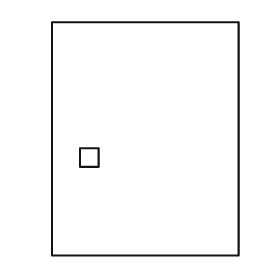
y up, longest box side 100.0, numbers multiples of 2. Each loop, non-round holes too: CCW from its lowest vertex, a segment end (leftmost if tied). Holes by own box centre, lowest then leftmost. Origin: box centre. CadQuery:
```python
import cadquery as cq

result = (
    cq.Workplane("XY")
    .moveTo(-40.0, -50.0)
    .lineTo(40.0, -50.0)
    .lineTo(40.0, 50.0)
    .lineTo(-40.0, 50.0)
    .close()
    .moveTo(-28.0, -12.0)
    .lineTo(-20.0, -12.0)
    .lineTo(-20.0, -4.0)
    .lineTo(-28.0, -4.0)
    .close()
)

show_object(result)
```